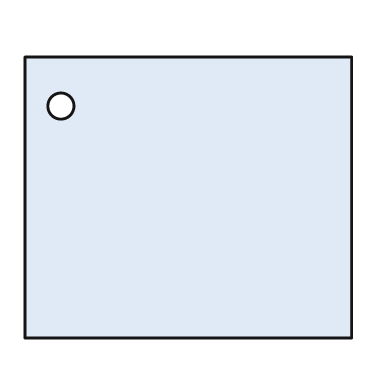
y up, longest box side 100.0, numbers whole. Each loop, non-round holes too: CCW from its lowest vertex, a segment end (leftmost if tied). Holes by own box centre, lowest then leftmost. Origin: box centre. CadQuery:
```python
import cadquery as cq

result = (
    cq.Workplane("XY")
    .moveTo(-50.0, -43.0)
    .lineTo(50.0, -43.0)
    .lineTo(50.0, 43.0)
    .lineTo(-50.0, 43.0)
    .close()
    .moveTo(-39.0, 28.0)
    .circle(4.0)
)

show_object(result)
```